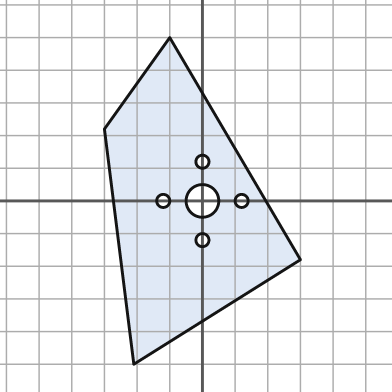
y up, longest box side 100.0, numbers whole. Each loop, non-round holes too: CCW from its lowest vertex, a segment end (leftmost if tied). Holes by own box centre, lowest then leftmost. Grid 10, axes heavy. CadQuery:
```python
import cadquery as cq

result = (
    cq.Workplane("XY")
    .moveTo(-21.0, -50.0)
    .lineTo(30.0, -18.0)
    .lineTo(-10.0, 50.0)
    .lineTo(-30.0, 22.0)
    .close()
    .moveTo(0.0, -12.0)
    .circle(2.0)
    .moveTo(-12.0, 0.0)
    .circle(2.0)
    .moveTo(0.0, 0.0)
    .circle(5.0)
    .moveTo(12.0, 0.0)
    .circle(2.0)
    .moveTo(0.0, 12.0)
    .circle(2.0)
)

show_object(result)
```